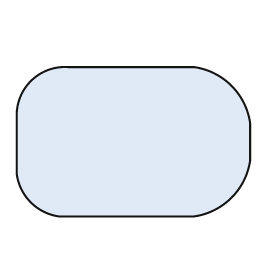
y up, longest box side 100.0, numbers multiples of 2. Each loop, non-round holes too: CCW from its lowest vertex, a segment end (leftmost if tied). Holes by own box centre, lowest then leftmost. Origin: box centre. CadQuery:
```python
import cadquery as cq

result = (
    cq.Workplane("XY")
    .moveTo(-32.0, -32.0)
    .lineTo(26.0, -32.0)
    .threePointArc((42.0, -24.0), (50.0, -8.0))
    .lineTo(50.0, 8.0)
    .threePointArc((42.0, 24.0), (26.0, 32.0))
    .lineTo(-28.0, 32.0)
    .threePointArc((-44.0, 26.0), (-50.0, 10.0))
    .lineTo(-50.0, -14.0)
    .threePointArc((-44.0, -26.0), (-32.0, -32.0))
    .close()
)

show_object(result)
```